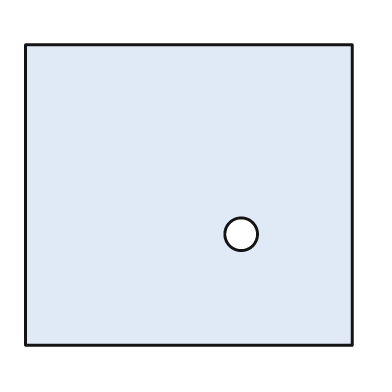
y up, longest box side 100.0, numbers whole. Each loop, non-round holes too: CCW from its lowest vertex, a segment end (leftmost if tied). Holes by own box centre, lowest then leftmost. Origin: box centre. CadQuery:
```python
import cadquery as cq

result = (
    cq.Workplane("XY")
    .moveTo(-50.0, -46.0)
    .lineTo(50.0, -46.0)
    .lineTo(50.0, 46.0)
    .lineTo(-50.0, 46.0)
    .close()
    .moveTo(16.0, -12.0)
    .circle(5.0)
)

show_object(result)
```